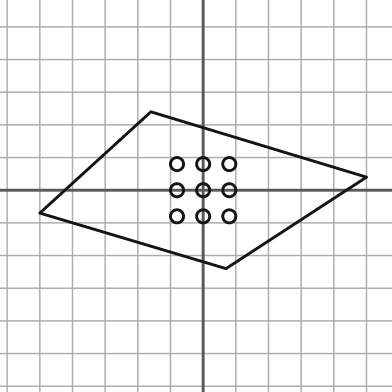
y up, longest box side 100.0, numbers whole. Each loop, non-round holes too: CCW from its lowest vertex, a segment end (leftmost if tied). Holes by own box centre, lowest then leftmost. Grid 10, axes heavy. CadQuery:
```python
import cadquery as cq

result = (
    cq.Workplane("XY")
    .moveTo(7.0, -24.0)
    .lineTo(50.0, 4.0)
    .lineTo(-16.0, 24.0)
    .lineTo(-50.0, -7.0)
    .close()
    .moveTo(-8.0, -8.0)
    .circle(2.0)
    .moveTo(0.0, -8.0)
    .circle(2.0)
    .moveTo(8.0, -8.0)
    .circle(2.0)
    .moveTo(-8.0, 0.0)
    .circle(2.0)
    .moveTo(0.0, 0.0)
    .circle(2.0)
    .moveTo(8.0, 0.0)
    .circle(2.0)
    .moveTo(-8.0, 8.0)
    .circle(2.0)
    .moveTo(0.0, 8.0)
    .circle(2.0)
    .moveTo(8.0, 8.0)
    .circle(2.0)
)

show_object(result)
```